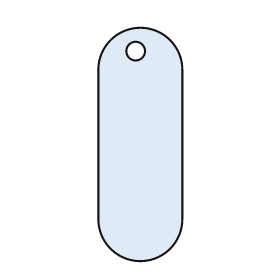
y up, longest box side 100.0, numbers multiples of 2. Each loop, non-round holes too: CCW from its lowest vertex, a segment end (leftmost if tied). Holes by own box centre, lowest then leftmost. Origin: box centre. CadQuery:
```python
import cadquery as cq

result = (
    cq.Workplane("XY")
    .moveTo(-18.0, -32.0)
    .threePointArc((0.0, -50.0), (18.0, -32.0))
    .lineTo(18.0, 32.0)
    .threePointArc((0.0, 50.0), (-18.0, 32.0))
    .close()
    .moveTo(-2.0, 40.0)
    .circle(4.0)
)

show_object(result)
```